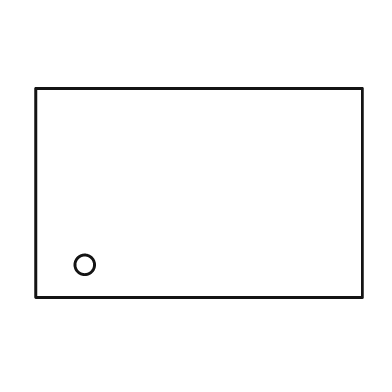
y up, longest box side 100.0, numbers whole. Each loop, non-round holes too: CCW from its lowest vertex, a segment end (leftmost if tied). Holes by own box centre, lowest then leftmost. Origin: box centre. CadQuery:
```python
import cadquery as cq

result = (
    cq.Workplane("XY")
    .moveTo(-50.0, -32.0)
    .lineTo(50.0, -32.0)
    .lineTo(50.0, 32.0)
    .lineTo(-50.0, 32.0)
    .close()
    .moveTo(-35.0, -22.0)
    .circle(3.0)
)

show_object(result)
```